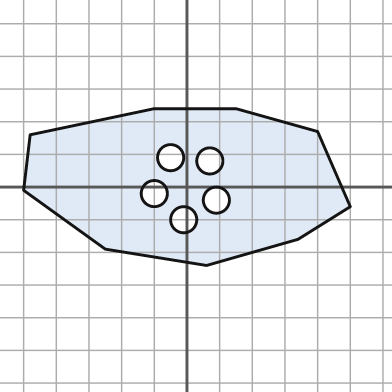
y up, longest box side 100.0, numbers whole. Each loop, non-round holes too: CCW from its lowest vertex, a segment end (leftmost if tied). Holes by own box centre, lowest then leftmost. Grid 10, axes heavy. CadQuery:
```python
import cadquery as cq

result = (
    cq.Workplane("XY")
    .moveTo(6.0, -24.0)
    .lineTo(34.0, -16.0)
    .lineTo(50.0, -6.0)
    .lineTo(40.0, 17.0)
    .lineTo(15.0, 24.0)
    .lineTo(-10.0, 24.0)
    .lineTo(-48.0, 16.0)
    .lineTo(-50.0, -1.0)
    .lineTo(-25.0, -19.0)
    .close()
    .moveTo(-1.0, -10.0)
    .circle(4.0)
    .moveTo(9.0, -4.0)
    .circle(4.0)
    .moveTo(-10.0, -2.0)
    .circle(4.0)
    .moveTo(7.0, 8.0)
    .circle(4.0)
    .moveTo(-5.0, 9.0)
    .circle(4.0)
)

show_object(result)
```